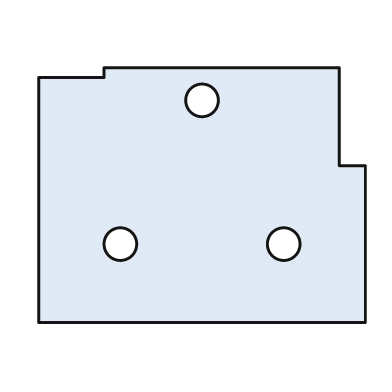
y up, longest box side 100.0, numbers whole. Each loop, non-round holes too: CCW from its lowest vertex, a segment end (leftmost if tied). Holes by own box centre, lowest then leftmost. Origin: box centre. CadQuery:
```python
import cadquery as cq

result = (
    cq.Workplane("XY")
    .moveTo(-50.0, -39.0)
    .lineTo(50.0, -39.0)
    .lineTo(50.0, 9.0)
    .lineTo(42.0, 9.0)
    .lineTo(42.0, 39.0)
    .lineTo(-30.0, 39.0)
    .lineTo(-30.0, 36.0)
    .lineTo(-50.0, 36.0)
    .close()
    .moveTo(-25.0, -15.0)
    .circle(5.0)
    .moveTo(25.0, -15.0)
    .circle(5.0)
    .moveTo(0.0, 29.0)
    .circle(5.0)
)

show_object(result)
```